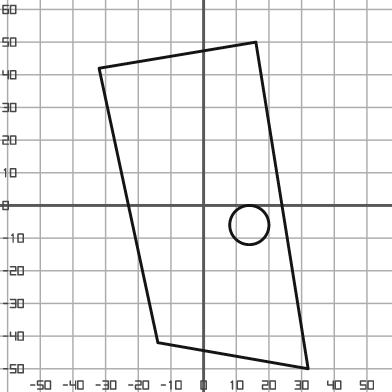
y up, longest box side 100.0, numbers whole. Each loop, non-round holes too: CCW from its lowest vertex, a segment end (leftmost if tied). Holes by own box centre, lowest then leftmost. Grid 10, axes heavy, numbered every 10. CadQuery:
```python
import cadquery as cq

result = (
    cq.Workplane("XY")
    .moveTo(32.0, -50.0)
    .lineTo(16.0, 50.0)
    .lineTo(-32.0, 42.0)
    .lineTo(-14.0, -42.0)
    .close()
    .moveTo(14.0, -6.0)
    .circle(6.0)
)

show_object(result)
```